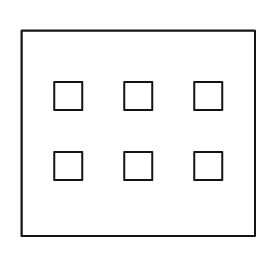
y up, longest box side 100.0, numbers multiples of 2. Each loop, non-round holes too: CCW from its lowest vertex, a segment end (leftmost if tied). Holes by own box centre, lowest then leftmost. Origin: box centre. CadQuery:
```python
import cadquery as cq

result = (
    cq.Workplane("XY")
    .moveTo(-50.0, -44.0)
    .lineTo(50.0, -44.0)
    .lineTo(50.0, 44.0)
    .lineTo(-50.0, 44.0)
    .close()
    .moveTo(-36.0, -20.0)
    .lineTo(-24.0, -20.0)
    .lineTo(-24.0, -8.0)
    .lineTo(-36.0, -8.0)
    .close()
    .moveTo(-6.0, -20.0)
    .lineTo(6.0, -20.0)
    .lineTo(6.0, -8.0)
    .lineTo(-6.0, -8.0)
    .close()
    .moveTo(24.0, -20.0)
    .lineTo(36.0, -20.0)
    .lineTo(36.0, -8.0)
    .lineTo(24.0, -8.0)
    .close()
    .moveTo(-36.0, 10.0)
    .lineTo(-24.0, 10.0)
    .lineTo(-24.0, 22.0)
    .lineTo(-36.0, 22.0)
    .close()
    .moveTo(-6.0, 10.0)
    .lineTo(6.0, 10.0)
    .lineTo(6.0, 22.0)
    .lineTo(-6.0, 22.0)
    .close()
    .moveTo(24.0, 10.0)
    .lineTo(36.0, 10.0)
    .lineTo(36.0, 22.0)
    .lineTo(24.0, 22.0)
    .close()
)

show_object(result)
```